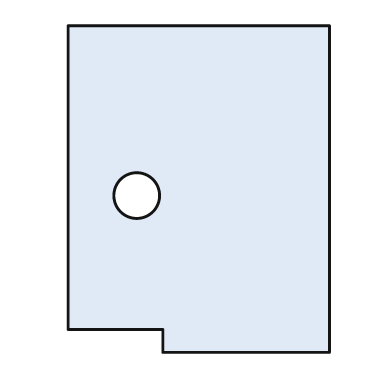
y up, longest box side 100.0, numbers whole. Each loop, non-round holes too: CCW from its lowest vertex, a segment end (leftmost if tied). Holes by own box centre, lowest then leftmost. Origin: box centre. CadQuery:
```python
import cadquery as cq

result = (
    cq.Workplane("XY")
    .moveTo(-11.0, -50.0)
    .lineTo(40.0, -50.0)
    .lineTo(40.0, 50.0)
    .lineTo(-40.0, 50.0)
    .lineTo(-40.0, -43.0)
    .lineTo(-11.0, -43.0)
    .close()
    .moveTo(-19.0, -2.0)
    .circle(7.0)
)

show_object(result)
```